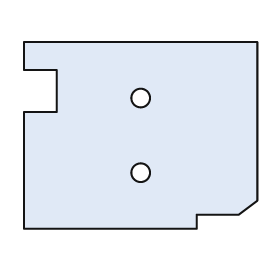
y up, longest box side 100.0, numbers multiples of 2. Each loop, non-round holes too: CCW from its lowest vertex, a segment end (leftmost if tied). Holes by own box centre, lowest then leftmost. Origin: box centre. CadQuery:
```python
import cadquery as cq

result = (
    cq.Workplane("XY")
    .moveTo(-50.0, -40.0)
    .lineTo(24.0, -40.0)
    .lineTo(24.0, -34.0)
    .lineTo(42.0, -34.0)
    .lineTo(50.0, -28.0)
    .lineTo(50.0, 40.0)
    .lineTo(-50.0, 40.0)
    .lineTo(-50.0, 28.0)
    .lineTo(-36.0, 28.0)
    .lineTo(-36.0, 10.0)
    .lineTo(-50.0, 10.0)
    .close()
    .moveTo(0.0, -16.0)
    .circle(4.0)
    .moveTo(0.0, 16.0)
    .circle(4.0)
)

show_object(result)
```